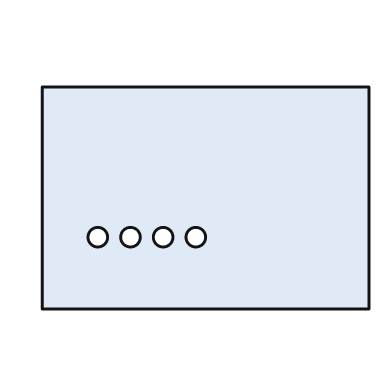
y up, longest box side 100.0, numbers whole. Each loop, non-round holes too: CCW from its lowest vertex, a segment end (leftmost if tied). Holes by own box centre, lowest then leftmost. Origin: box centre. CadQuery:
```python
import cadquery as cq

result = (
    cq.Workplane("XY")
    .moveTo(-50.0, -34.0)
    .lineTo(50.0, -34.0)
    .lineTo(50.0, 34.0)
    .lineTo(-50.0, 34.0)
    .close()
    .moveTo(-33.0, -12.0)
    .circle(3.0)
    .moveTo(-23.0, -12.0)
    .circle(3.0)
    .moveTo(-13.0, -12.0)
    .circle(3.0)
    .moveTo(-3.0, -12.0)
    .circle(3.0)
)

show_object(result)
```